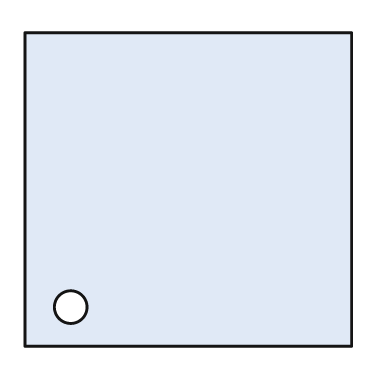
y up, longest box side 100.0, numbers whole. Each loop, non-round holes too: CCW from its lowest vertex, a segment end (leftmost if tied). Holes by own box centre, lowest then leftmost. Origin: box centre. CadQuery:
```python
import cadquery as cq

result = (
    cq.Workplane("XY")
    .moveTo(-50.0, -48.0)
    .lineTo(50.0, -48.0)
    .lineTo(50.0, 48.0)
    .lineTo(-50.0, 48.0)
    .close()
    .moveTo(-36.0, -36.0)
    .circle(5.0)
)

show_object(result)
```